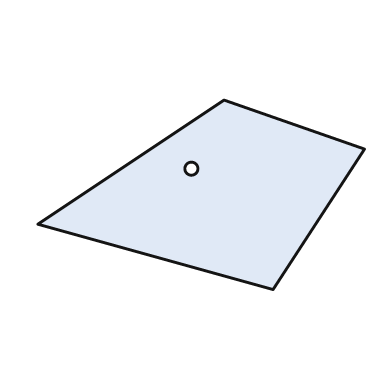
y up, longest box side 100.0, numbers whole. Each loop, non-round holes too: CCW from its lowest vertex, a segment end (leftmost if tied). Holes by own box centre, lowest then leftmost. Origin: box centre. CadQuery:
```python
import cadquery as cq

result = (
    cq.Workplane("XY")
    .moveTo(22.0, -29.0)
    .lineTo(50.0, 14.0)
    .lineTo(7.0, 29.0)
    .lineTo(-50.0, -9.0)
    .close()
    .moveTo(-3.0, 8.0)
    .circle(2.0)
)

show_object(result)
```